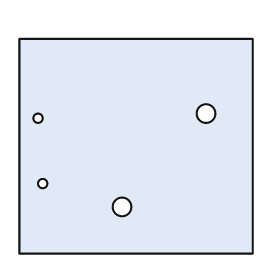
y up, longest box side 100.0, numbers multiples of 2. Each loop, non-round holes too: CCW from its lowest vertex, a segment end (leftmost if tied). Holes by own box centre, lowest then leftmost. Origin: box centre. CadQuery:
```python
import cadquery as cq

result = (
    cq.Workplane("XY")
    .moveTo(-50.0, -46.0)
    .lineTo(50.0, -46.0)
    .lineTo(50.0, 46.0)
    .lineTo(-50.0, 46.0)
    .close()
    .moveTo(-6.0, -26.0)
    .circle(4.0)
    .moveTo(-40.0, -16.0)
    .circle(2.0)
    .moveTo(-42.0, 12.0)
    .circle(2.0)
    .moveTo(30.0, 14.0)
    .circle(4.0)
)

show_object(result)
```